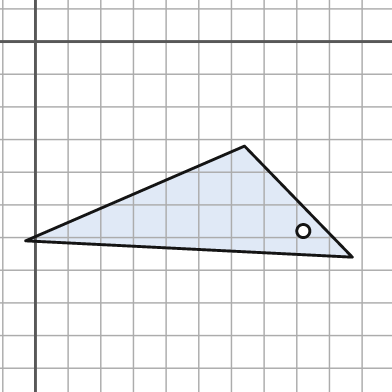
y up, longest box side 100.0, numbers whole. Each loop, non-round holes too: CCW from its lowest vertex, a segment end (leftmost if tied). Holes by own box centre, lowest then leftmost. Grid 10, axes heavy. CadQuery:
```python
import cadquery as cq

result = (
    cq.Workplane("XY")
    .moveTo(97.0, -66.0)
    .lineTo(64.0, -32.0)
    .lineTo(-3.0, -61.0)
    .close()
    .moveTo(82.0, -58.0)
    .circle(2.0)
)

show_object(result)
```